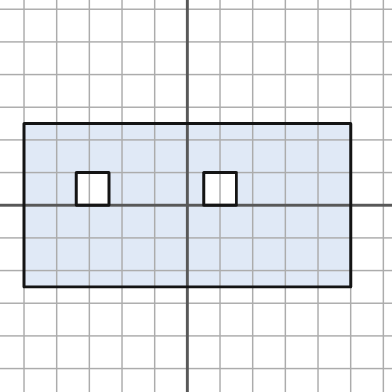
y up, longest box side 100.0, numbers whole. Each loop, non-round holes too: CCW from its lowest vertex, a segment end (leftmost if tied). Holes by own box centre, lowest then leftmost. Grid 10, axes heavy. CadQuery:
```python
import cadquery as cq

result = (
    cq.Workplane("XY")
    .moveTo(-50.0, -25.0)
    .lineTo(50.0, -25.0)
    .lineTo(50.0, 25.0)
    .lineTo(-50.0, 25.0)
    .close()
    .moveTo(-34.0, 0.0)
    .lineTo(-24.0, 0.0)
    .lineTo(-24.0, 10.0)
    .lineTo(-34.0, 10.0)
    .close()
    .moveTo(5.0, 0.0)
    .lineTo(15.0, 0.0)
    .lineTo(15.0, 10.0)
    .lineTo(5.0, 10.0)
    .close()
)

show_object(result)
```